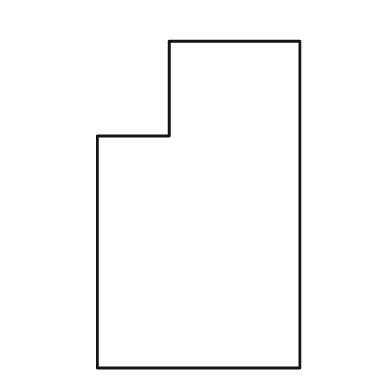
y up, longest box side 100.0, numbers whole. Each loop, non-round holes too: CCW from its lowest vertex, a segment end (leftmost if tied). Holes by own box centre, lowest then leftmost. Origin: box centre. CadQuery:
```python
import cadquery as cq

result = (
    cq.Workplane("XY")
    .moveTo(-31.0, -50.0)
    .lineTo(31.0, -50.0)
    .lineTo(31.0, 50.0)
    .lineTo(-9.0, 50.0)
    .lineTo(-9.0, 21.0)
    .lineTo(-31.0, 21.0)
    .close()
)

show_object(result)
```